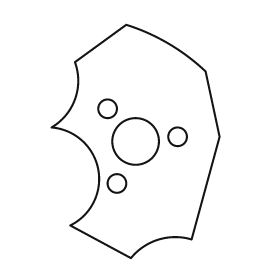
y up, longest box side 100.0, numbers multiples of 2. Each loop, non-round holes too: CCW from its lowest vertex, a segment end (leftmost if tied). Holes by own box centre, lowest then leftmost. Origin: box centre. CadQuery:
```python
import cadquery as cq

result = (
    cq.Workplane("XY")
    .moveTo(-2.0, -50.0)
    .threePointArc((10.0, -42.0), (24.0, -42.0))
    .lineTo(36.0, 2.0)
    .lineTo(30.0, 30.0)
    .threePointArc((14.0, 42.0), (-4.0, 50.0))
    .lineTo(-26.0, 34.0)
    .threePointArc((-26.0, 18.0), (-36.0, 6.0))
    .threePointArc((-16.0, -12.0), (-28.0, -36.0))
    .close()
    .moveTo(-8.0, -18.0)
    .circle(4.0)
    .moveTo(0.0, 0.0)
    .circle(10.0)
    .moveTo(18.0, 2.0)
    .circle(4.0)
    .moveTo(-12.0, 14.0)
    .circle(4.0)
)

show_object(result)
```